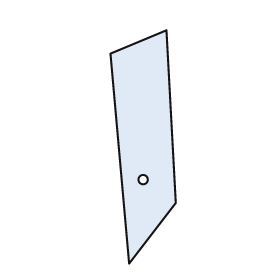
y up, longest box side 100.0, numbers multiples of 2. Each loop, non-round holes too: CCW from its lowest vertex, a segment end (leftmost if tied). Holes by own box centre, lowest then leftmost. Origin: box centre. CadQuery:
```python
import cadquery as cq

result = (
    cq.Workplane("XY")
    .moveTo(-6.0, -50.0)
    .lineTo(14.0, -24.0)
    .lineTo(10.0, 50.0)
    .lineTo(-14.0, 40.0)
    .close()
    .moveTo(0.0, -14.0)
    .circle(2.0)
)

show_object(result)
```